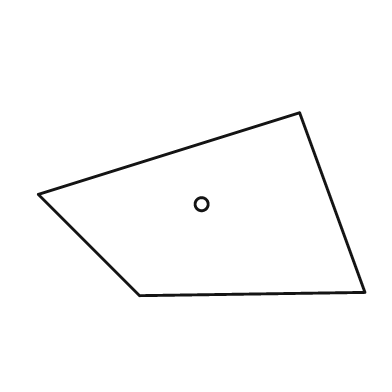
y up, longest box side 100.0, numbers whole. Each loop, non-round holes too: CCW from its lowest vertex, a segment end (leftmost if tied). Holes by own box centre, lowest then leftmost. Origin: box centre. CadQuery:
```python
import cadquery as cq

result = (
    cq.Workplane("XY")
    .moveTo(-19.0, -28.0)
    .lineTo(50.0, -27.0)
    .lineTo(30.0, 28.0)
    .lineTo(-50.0, 3.0)
    .close()
    .moveTo(0.0, 0.0)
    .circle(2.0)
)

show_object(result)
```